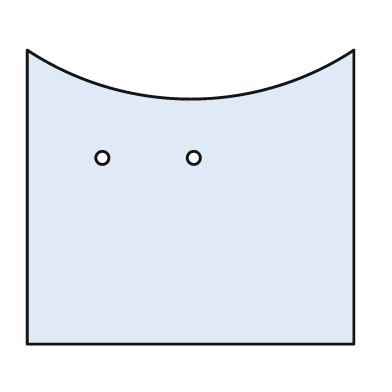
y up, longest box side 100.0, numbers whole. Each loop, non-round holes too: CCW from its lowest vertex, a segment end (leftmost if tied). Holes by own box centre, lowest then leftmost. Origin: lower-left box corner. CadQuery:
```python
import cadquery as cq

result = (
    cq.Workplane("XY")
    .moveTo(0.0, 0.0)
    .lineTo(100.0, 0.0)
    .lineTo(100.0, 90.0)
    .threePointArc((50.0, 75.0), (0.0, 90.0))
    .close()
    .moveTo(23.0, 57.0)
    .circle(2.0)
    .moveTo(51.0, 57.0)
    .circle(2.0)
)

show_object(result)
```